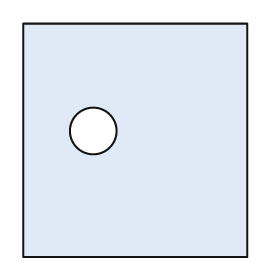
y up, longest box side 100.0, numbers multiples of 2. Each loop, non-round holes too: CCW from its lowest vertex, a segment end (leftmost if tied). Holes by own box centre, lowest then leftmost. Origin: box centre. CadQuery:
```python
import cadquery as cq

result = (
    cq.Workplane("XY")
    .moveTo(-48.0, -50.0)
    .lineTo(48.0, -50.0)
    .lineTo(48.0, 50.0)
    .lineTo(-48.0, 50.0)
    .close()
    .moveTo(-18.0, 4.0)
    .circle(10.0)
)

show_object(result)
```